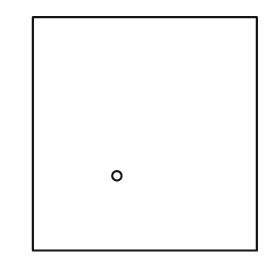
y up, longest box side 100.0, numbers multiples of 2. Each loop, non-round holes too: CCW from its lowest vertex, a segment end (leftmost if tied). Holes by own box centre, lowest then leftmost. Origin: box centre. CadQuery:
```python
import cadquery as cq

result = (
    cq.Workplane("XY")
    .moveTo(-48.0, -50.0)
    .lineTo(48.0, -50.0)
    .lineTo(48.0, 50.0)
    .lineTo(-48.0, 50.0)
    .close()
    .moveTo(-12.0, -18.0)
    .circle(2.0)
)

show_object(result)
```